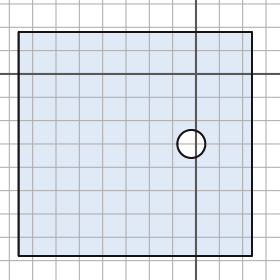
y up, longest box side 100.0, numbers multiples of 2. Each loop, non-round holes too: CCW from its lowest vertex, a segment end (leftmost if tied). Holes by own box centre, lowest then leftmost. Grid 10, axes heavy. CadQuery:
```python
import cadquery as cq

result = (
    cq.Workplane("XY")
    .moveTo(-76.0, -78.0)
    .lineTo(24.0, -78.0)
    .lineTo(24.0, 18.0)
    .lineTo(-76.0, 18.0)
    .close()
    .moveTo(-2.0, -30.0)
    .circle(6.0)
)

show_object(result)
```